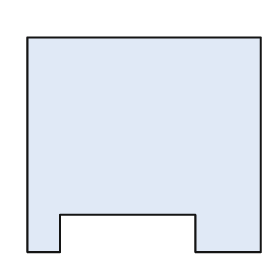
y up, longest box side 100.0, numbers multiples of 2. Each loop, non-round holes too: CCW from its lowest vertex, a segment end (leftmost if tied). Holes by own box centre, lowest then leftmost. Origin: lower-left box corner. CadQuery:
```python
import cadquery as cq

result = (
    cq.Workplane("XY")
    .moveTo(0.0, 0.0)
    .lineTo(14.0, 0.0)
    .lineTo(14.0, 16.0)
    .lineTo(72.0, 16.0)
    .lineTo(72.0, 0.0)
    .lineTo(100.0, 0.0)
    .lineTo(100.0, 92.0)
    .lineTo(0.0, 92.0)
    .close()
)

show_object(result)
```